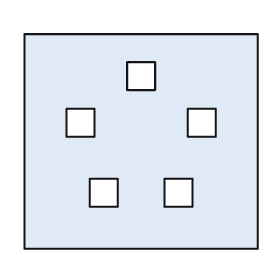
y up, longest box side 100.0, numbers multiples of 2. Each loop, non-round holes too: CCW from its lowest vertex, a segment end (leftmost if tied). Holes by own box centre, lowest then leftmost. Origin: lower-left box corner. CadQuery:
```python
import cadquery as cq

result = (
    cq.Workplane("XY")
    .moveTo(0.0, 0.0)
    .lineTo(100.0, 0.0)
    .lineTo(100.0, 92.0)
    .lineTo(0.0, 92.0)
    .close()
    .moveTo(28.0, 18.0)
    .lineTo(40.0, 18.0)
    .lineTo(40.0, 30.0)
    .lineTo(28.0, 30.0)
    .close()
    .moveTo(60.0, 18.0)
    .lineTo(72.0, 18.0)
    .lineTo(72.0, 30.0)
    .lineTo(60.0, 30.0)
    .close()
    .moveTo(18.0, 48.0)
    .lineTo(30.0, 48.0)
    .lineTo(30.0, 60.0)
    .lineTo(18.0, 60.0)
    .close()
    .moveTo(70.0, 48.0)
    .lineTo(82.0, 48.0)
    .lineTo(82.0, 60.0)
    .lineTo(70.0, 60.0)
    .close()
    .moveTo(44.0, 68.0)
    .lineTo(56.0, 68.0)
    .lineTo(56.0, 80.0)
    .lineTo(44.0, 80.0)
    .close()
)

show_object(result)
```